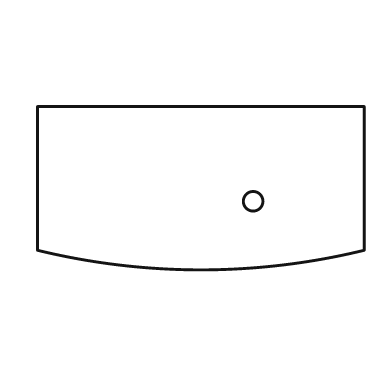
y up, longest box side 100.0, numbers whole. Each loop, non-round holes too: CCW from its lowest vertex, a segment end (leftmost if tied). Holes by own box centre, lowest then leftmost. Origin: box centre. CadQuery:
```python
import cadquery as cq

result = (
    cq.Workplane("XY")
    .moveTo(-50.0, -19.0)
    .threePointArc((0.0, -25.0), (50.0, -19.0))
    .lineTo(50.0, 25.0)
    .lineTo(-50.0, 25.0)
    .close()
    .moveTo(16.0, -4.0)
    .circle(3.0)
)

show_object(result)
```